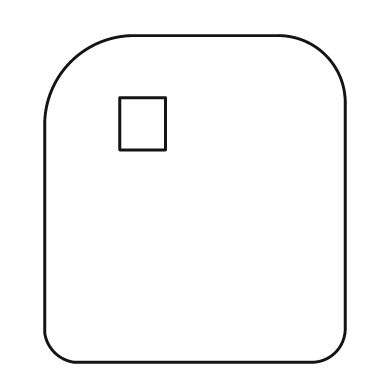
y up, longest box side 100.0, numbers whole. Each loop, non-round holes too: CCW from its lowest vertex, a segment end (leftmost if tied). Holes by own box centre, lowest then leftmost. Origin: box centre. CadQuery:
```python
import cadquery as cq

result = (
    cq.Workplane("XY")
    .moveTo(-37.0, -50.0)
    .lineTo(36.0, -50.0)
    .threePointArc((43.0, -47.0), (46.0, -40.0))
    .lineTo(46.0, 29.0)
    .threePointArc((40.0, 44.0), (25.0, 50.0))
    .lineTo(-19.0, 50.0)
    .threePointArc((-38.0, 42.0), (-46.0, 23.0))
    .lineTo(-46.0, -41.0)
    .threePointArc((-43.0, -47.0), (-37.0, -50.0))
    .close()
    .moveTo(-23.0, 15.0)
    .lineTo(-9.0, 15.0)
    .lineTo(-9.0, 31.0)
    .lineTo(-23.0, 31.0)
    .close()
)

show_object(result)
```